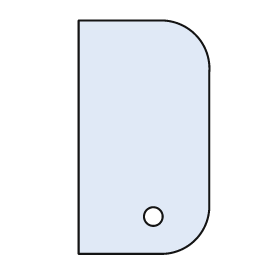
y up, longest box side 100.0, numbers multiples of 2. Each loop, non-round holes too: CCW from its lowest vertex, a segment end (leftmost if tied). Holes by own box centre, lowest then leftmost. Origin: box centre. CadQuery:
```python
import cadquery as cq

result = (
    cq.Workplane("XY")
    .moveTo(-28.0, -50.0)
    .lineTo(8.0, -50.0)
    .threePointArc((22.0, -44.0), (28.0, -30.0))
    .lineTo(28.0, 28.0)
    .threePointArc((22.0, 44.0), (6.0, 50.0))
    .lineTo(-28.0, 50.0)
    .close()
    .moveTo(4.0, -34.0)
    .circle(4.0)
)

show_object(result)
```